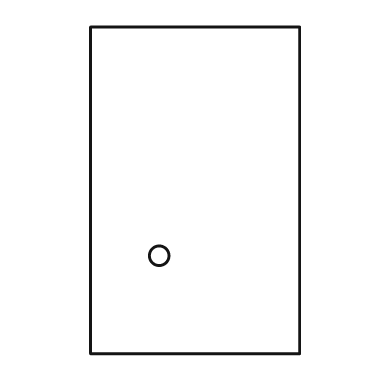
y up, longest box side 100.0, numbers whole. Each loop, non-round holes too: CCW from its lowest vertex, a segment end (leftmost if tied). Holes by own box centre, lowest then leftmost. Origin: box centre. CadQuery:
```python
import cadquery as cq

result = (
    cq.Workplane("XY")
    .moveTo(-32.0, -50.0)
    .lineTo(32.0, -50.0)
    .lineTo(32.0, 50.0)
    .lineTo(-32.0, 50.0)
    .close()
    .moveTo(-11.0, -20.0)
    .circle(3.0)
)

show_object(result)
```